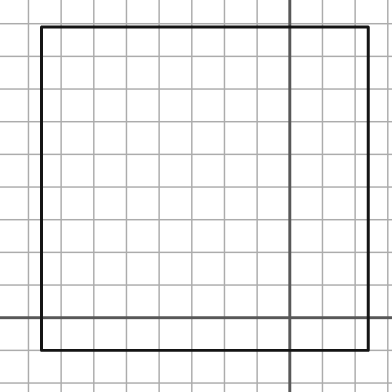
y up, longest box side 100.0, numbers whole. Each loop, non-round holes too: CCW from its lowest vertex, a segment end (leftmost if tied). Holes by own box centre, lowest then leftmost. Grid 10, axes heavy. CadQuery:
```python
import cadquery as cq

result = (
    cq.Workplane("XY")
    .moveTo(-76.0, -10.0)
    .lineTo(24.0, -10.0)
    .lineTo(24.0, 89.0)
    .lineTo(-76.0, 89.0)
    .close()
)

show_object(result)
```